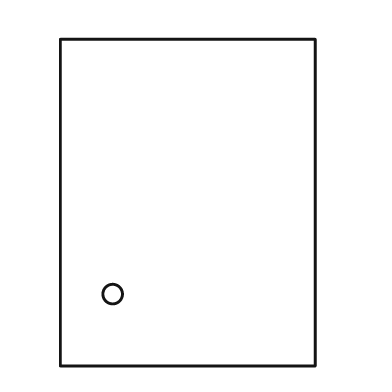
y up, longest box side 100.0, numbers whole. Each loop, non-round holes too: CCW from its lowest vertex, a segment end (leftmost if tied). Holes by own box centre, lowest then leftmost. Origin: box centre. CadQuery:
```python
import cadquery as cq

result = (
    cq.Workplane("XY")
    .moveTo(-39.0, -50.0)
    .lineTo(39.0, -50.0)
    .lineTo(39.0, 50.0)
    .lineTo(-39.0, 50.0)
    .close()
    .moveTo(-23.0, -28.0)
    .circle(3.0)
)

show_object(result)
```